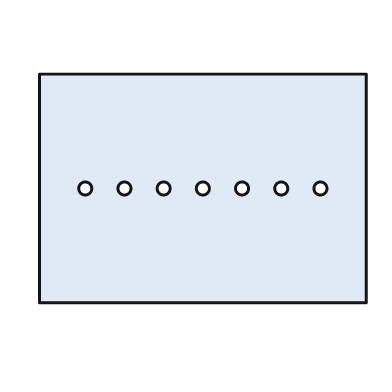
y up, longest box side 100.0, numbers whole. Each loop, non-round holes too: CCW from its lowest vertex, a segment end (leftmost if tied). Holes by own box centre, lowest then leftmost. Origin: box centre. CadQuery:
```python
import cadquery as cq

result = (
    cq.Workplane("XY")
    .moveTo(-50.0, -35.0)
    .lineTo(50.0, -35.0)
    .lineTo(50.0, 35.0)
    .lineTo(-50.0, 35.0)
    .close()
    .moveTo(-36.0, 0.0)
    .circle(2.0)
    .moveTo(-24.0, 0.0)
    .circle(2.0)
    .moveTo(-12.0, 0.0)
    .circle(2.0)
    .moveTo(0.0, 0.0)
    .circle(2.0)
    .moveTo(12.0, 0.0)
    .circle(2.0)
    .moveTo(24.0, 0.0)
    .circle(2.0)
    .moveTo(36.0, 0.0)
    .circle(2.0)
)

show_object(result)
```